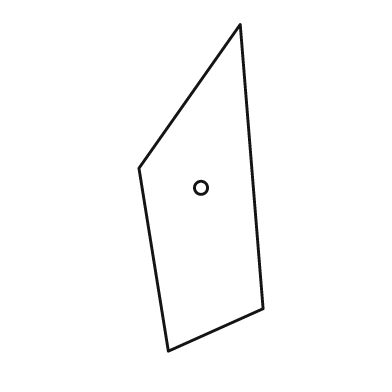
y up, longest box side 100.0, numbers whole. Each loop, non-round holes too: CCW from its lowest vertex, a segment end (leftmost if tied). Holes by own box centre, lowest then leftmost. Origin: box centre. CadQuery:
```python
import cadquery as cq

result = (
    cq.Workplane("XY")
    .moveTo(-10.0, -50.0)
    .lineTo(19.0, -37.0)
    .lineTo(12.0, 50.0)
    .lineTo(-19.0, 6.0)
    .close()
    .moveTo(0.0, 0.0)
    .circle(2.0)
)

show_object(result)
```